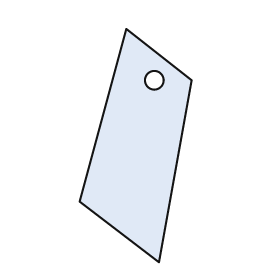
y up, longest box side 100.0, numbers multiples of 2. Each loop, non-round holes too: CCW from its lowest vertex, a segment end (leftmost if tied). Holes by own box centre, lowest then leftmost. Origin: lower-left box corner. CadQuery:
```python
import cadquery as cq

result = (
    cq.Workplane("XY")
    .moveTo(34.0, 0.0)
    .lineTo(48.0, 78.0)
    .lineTo(20.0, 100.0)
    .lineTo(0.0, 26.0)
    .close()
    .moveTo(32.0, 78.0)
    .circle(4.0)
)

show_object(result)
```